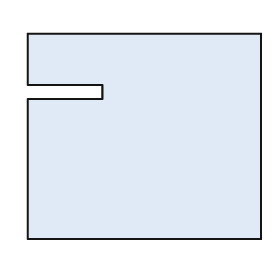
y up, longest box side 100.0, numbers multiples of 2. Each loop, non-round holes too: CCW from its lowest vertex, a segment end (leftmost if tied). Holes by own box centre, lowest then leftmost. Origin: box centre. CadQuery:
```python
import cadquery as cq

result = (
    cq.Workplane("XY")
    .moveTo(-50.0, -44.0)
    .lineTo(50.0, -44.0)
    .lineTo(50.0, 44.0)
    .lineTo(-50.0, 44.0)
    .lineTo(-50.0, 22.0)
    .lineTo(-18.0, 22.0)
    .lineTo(-18.0, 16.0)
    .lineTo(-50.0, 16.0)
    .close()
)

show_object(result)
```